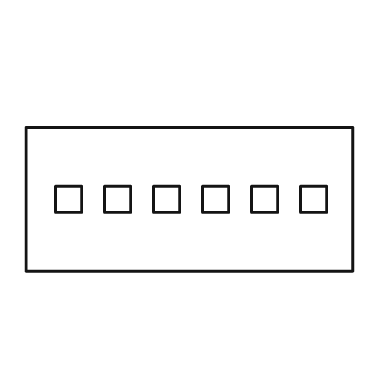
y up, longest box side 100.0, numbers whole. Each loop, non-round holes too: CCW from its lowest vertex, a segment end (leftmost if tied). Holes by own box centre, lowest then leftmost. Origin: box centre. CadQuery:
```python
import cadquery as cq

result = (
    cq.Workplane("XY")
    .moveTo(-50.0, -22.0)
    .lineTo(50.0, -22.0)
    .lineTo(50.0, 22.0)
    .lineTo(-50.0, 22.0)
    .close()
    .moveTo(-41.0, -4.0)
    .lineTo(-33.0, -4.0)
    .lineTo(-33.0, 4.0)
    .lineTo(-41.0, 4.0)
    .close()
    .moveTo(-26.0, -4.0)
    .lineTo(-18.0, -4.0)
    .lineTo(-18.0, 4.0)
    .lineTo(-26.0, 4.0)
    .close()
    .moveTo(-11.0, -4.0)
    .lineTo(-3.0, -4.0)
    .lineTo(-3.0, 4.0)
    .lineTo(-11.0, 4.0)
    .close()
    .moveTo(4.0, -4.0)
    .lineTo(12.0, -4.0)
    .lineTo(12.0, 4.0)
    .lineTo(4.0, 4.0)
    .close()
    .moveTo(19.0, -4.0)
    .lineTo(27.0, -4.0)
    .lineTo(27.0, 4.0)
    .lineTo(19.0, 4.0)
    .close()
    .moveTo(34.0, -4.0)
    .lineTo(42.0, -4.0)
    .lineTo(42.0, 4.0)
    .lineTo(34.0, 4.0)
    .close()
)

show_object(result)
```